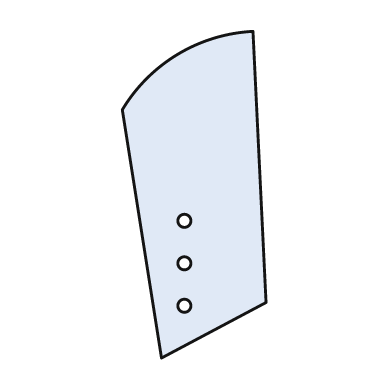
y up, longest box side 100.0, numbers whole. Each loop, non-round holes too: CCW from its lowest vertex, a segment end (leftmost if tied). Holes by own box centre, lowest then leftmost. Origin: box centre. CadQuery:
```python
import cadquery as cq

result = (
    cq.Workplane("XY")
    .moveTo(-10.0, -50.0)
    .lineTo(22.0, -33.0)
    .lineTo(18.0, 50.0)
    .threePointArc((-5.0, 43.0), (-22.0, 26.0))
    .close()
    .moveTo(-3.0, -34.0)
    .circle(2.0)
    .moveTo(-3.0, -21.0)
    .circle(2.0)
    .moveTo(-3.0, -8.0)
    .circle(2.0)
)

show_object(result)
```